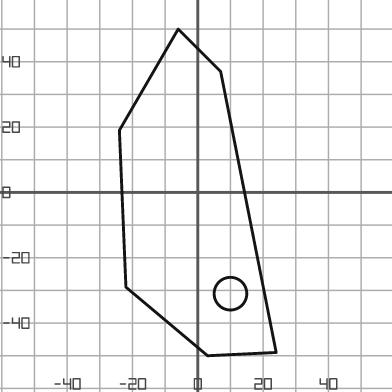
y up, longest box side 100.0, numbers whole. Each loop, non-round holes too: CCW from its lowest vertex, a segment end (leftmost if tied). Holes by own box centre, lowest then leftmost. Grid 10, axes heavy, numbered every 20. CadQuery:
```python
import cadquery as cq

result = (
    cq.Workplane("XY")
    .moveTo(3.0, -50.0)
    .lineTo(24.0, -49.0)
    .lineTo(7.0, 37.0)
    .lineTo(-6.0, 50.0)
    .lineTo(-24.0, 19.0)
    .lineTo(-22.0, -29.0)
    .close()
    .moveTo(10.0, -31.0)
    .circle(5.0)
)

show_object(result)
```